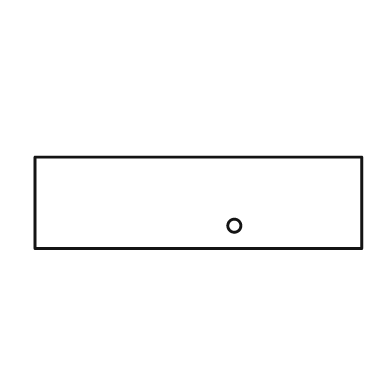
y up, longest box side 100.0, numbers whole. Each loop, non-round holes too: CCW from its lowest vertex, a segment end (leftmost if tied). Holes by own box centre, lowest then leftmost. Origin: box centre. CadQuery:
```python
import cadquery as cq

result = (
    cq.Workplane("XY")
    .moveTo(-50.0, -14.0)
    .lineTo(50.0, -14.0)
    .lineTo(50.0, 14.0)
    .lineTo(-50.0, 14.0)
    .close()
    .moveTo(11.0, -7.0)
    .circle(2.0)
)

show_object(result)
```